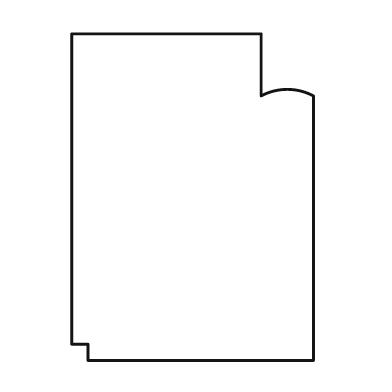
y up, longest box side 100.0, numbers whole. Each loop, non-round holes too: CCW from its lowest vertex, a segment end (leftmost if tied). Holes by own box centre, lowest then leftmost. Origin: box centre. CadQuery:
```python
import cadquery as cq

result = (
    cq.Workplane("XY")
    .moveTo(-32.0, -50.0)
    .lineTo(37.0, -50.0)
    .lineTo(37.0, 31.0)
    .threePointArc((29.0, 33.0), (21.0, 31.0))
    .lineTo(21.0, 50.0)
    .lineTo(-37.0, 50.0)
    .lineTo(-37.0, -45.0)
    .lineTo(-32.0, -45.0)
    .close()
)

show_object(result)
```